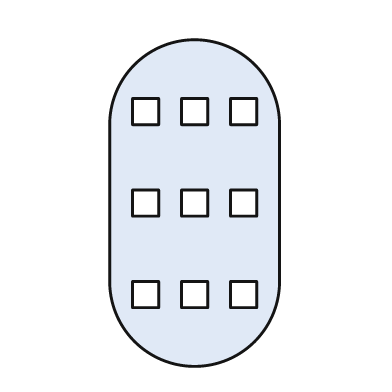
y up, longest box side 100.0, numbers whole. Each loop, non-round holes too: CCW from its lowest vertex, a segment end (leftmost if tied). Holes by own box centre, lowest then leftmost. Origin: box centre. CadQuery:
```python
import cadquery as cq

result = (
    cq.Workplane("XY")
    .moveTo(-26.0, -24.0)
    .threePointArc((0.0, -50.0), (26.0, -24.0))
    .lineTo(26.0, 24.0)
    .threePointArc((0.0, 50.0), (-26.0, 24.0))
    .close()
    .moveTo(-19.0, -32.0)
    .lineTo(-11.0, -32.0)
    .lineTo(-11.0, -24.0)
    .lineTo(-19.0, -24.0)
    .close()
    .moveTo(-4.0, -32.0)
    .lineTo(4.0, -32.0)
    .lineTo(4.0, -24.0)
    .lineTo(-4.0, -24.0)
    .close()
    .moveTo(11.0, -32.0)
    .lineTo(19.0, -32.0)
    .lineTo(19.0, -24.0)
    .lineTo(11.0, -24.0)
    .close()
    .moveTo(-19.0, -4.0)
    .lineTo(-11.0, -4.0)
    .lineTo(-11.0, 4.0)
    .lineTo(-19.0, 4.0)
    .close()
    .moveTo(-4.0, -4.0)
    .lineTo(4.0, -4.0)
    .lineTo(4.0, 4.0)
    .lineTo(-4.0, 4.0)
    .close()
    .moveTo(11.0, -4.0)
    .lineTo(19.0, -4.0)
    .lineTo(19.0, 4.0)
    .lineTo(11.0, 4.0)
    .close()
    .moveTo(-19.0, 24.0)
    .lineTo(-11.0, 24.0)
    .lineTo(-11.0, 32.0)
    .lineTo(-19.0, 32.0)
    .close()
    .moveTo(-4.0, 24.0)
    .lineTo(4.0, 24.0)
    .lineTo(4.0, 32.0)
    .lineTo(-4.0, 32.0)
    .close()
    .moveTo(11.0, 24.0)
    .lineTo(19.0, 24.0)
    .lineTo(19.0, 32.0)
    .lineTo(11.0, 32.0)
    .close()
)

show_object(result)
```